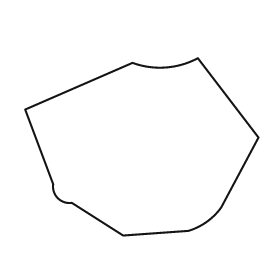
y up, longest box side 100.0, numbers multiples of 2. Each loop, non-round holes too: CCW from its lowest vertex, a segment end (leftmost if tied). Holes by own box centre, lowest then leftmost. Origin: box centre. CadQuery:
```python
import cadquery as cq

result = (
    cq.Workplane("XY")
    .moveTo(-8.0, -38.0)
    .lineTo(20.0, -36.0)
    .threePointArc((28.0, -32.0), (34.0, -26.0))
    .lineTo(50.0, 4.0)
    .lineTo(24.0, 38.0)
    .threePointArc((10.0, 34.0), (-4.0, 36.0))
    .lineTo(-50.0, 16.0)
    .lineTo(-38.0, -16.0)
    .threePointArc((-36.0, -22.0), (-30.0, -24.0))
    .close()
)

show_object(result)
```